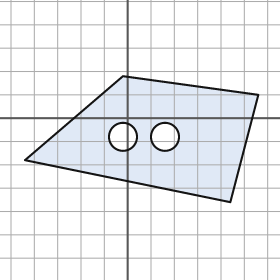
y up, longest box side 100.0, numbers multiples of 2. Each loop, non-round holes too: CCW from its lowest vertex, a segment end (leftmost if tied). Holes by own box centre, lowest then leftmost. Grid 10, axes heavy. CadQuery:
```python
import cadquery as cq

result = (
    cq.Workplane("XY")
    .moveTo(44.0, -36.0)
    .lineTo(56.0, 10.0)
    .lineTo(-2.0, 18.0)
    .lineTo(-44.0, -18.0)
    .close()
    .moveTo(-2.0, -8.0)
    .circle(6.0)
    .moveTo(16.0, -8.0)
    .circle(6.0)
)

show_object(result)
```